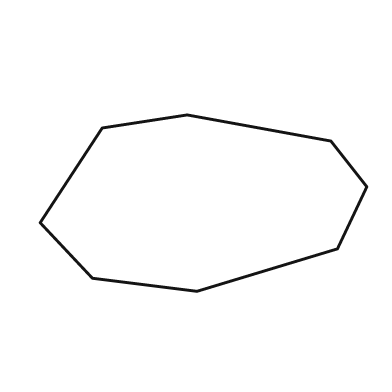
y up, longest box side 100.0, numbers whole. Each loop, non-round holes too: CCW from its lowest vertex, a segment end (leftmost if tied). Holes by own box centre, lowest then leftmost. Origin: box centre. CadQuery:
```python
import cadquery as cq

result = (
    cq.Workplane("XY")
    .moveTo(-2.0, -27.0)
    .lineTo(41.0, -14.0)
    .lineTo(50.0, 5.0)
    .lineTo(39.0, 19.0)
    .lineTo(-5.0, 27.0)
    .lineTo(-31.0, 23.0)
    .lineTo(-50.0, -6.0)
    .lineTo(-34.0, -23.0)
    .close()
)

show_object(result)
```